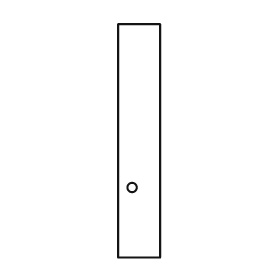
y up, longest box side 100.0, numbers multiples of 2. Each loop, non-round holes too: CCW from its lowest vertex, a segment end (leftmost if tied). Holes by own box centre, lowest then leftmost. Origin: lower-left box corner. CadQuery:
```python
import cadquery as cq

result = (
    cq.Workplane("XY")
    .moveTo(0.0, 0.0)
    .lineTo(18.0, 0.0)
    .lineTo(18.0, 100.0)
    .lineTo(0.0, 100.0)
    .close()
    .moveTo(6.0, 30.0)
    .circle(2.0)
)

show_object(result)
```